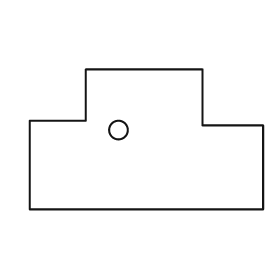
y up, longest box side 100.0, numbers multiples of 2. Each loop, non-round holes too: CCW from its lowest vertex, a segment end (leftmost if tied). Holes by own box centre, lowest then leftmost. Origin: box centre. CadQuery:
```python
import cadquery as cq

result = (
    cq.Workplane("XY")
    .moveTo(-50.0, -30.0)
    .lineTo(50.0, -30.0)
    .lineTo(50.0, 6.0)
    .lineTo(24.0, 6.0)
    .lineTo(24.0, 30.0)
    .lineTo(-26.0, 30.0)
    .lineTo(-26.0, 8.0)
    .lineTo(-50.0, 8.0)
    .close()
    .moveTo(-12.0, 4.0)
    .circle(4.0)
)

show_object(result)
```